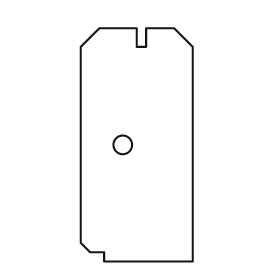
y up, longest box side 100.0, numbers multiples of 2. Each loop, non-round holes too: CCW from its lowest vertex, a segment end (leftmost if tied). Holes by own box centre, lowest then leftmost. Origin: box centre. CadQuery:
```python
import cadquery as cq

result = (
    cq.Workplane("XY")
    .moveTo(-14.0, -50.0)
    .lineTo(24.0, -50.0)
    .lineTo(24.0, 42.0)
    .lineTo(16.0, 50.0)
    .lineTo(4.0, 50.0)
    .lineTo(4.0, 42.0)
    .lineTo(0.0, 42.0)
    .lineTo(0.0, 50.0)
    .lineTo(-16.0, 50.0)
    .lineTo(-24.0, 42.0)
    .lineTo(-24.0, -42.0)
    .lineTo(-20.0, -46.0)
    .lineTo(-14.0, -46.0)
    .close()
    .moveTo(-6.0, 0.0)
    .circle(4.0)
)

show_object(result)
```